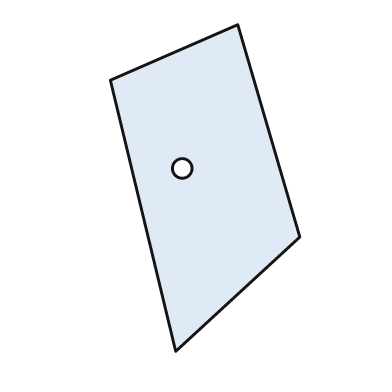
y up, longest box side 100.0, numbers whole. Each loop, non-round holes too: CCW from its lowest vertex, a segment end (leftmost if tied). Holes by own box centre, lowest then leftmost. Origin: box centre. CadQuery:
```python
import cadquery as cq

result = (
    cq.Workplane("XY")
    .moveTo(-9.0, -50.0)
    .lineTo(29.0, -15.0)
    .lineTo(10.0, 50.0)
    .lineTo(-29.0, 33.0)
    .close()
    .moveTo(-7.0, 6.0)
    .circle(3.0)
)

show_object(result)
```